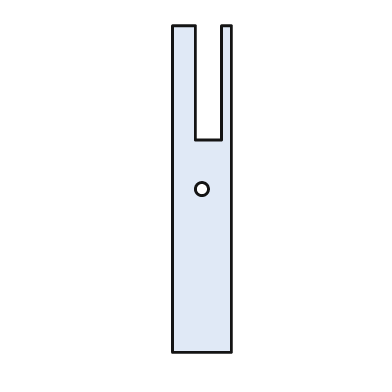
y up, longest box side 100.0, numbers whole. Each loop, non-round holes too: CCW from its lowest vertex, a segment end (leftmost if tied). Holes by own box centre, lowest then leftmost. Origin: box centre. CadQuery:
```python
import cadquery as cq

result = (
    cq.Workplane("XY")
    .moveTo(-9.0, -50.0)
    .lineTo(9.0, -50.0)
    .lineTo(9.0, 50.0)
    .lineTo(6.0, 50.0)
    .lineTo(6.0, 15.0)
    .lineTo(-2.0, 15.0)
    .lineTo(-2.0, 50.0)
    .lineTo(-9.0, 50.0)
    .close()
    .moveTo(0.0, 0.0)
    .circle(2.0)
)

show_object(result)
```